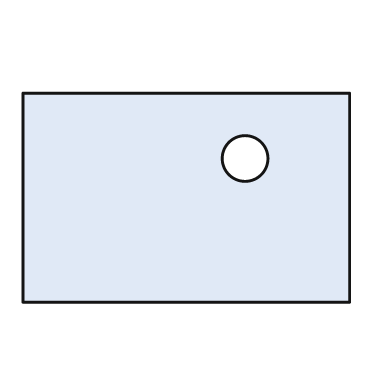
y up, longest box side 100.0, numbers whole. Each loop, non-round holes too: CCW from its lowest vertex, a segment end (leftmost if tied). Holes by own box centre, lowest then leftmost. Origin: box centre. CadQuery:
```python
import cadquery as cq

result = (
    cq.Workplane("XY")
    .moveTo(-50.0, -32.0)
    .lineTo(50.0, -32.0)
    .lineTo(50.0, 32.0)
    .lineTo(-50.0, 32.0)
    .close()
    .moveTo(18.0, 12.0)
    .circle(7.0)
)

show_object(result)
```